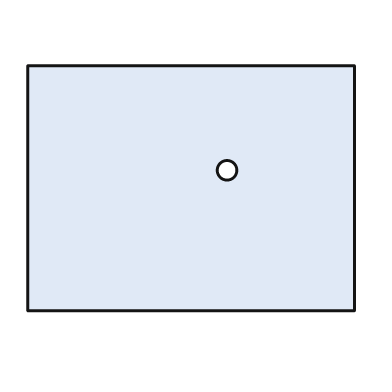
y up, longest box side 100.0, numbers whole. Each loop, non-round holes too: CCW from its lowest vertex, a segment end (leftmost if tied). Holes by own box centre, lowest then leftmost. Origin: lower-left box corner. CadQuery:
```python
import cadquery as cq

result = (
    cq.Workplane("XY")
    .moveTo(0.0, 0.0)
    .lineTo(100.0, 0.0)
    .lineTo(100.0, 75.0)
    .lineTo(0.0, 75.0)
    .close()
    .moveTo(61.0, 43.0)
    .circle(3.0)
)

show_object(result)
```